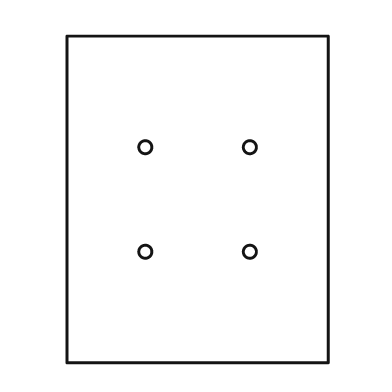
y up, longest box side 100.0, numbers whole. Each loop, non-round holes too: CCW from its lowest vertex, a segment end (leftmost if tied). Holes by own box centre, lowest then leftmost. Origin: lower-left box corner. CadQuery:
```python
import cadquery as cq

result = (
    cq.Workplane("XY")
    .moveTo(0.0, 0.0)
    .lineTo(80.0, 0.0)
    .lineTo(80.0, 100.0)
    .lineTo(0.0, 100.0)
    .close()
    .moveTo(24.0, 34.0)
    .circle(2.0)
    .moveTo(56.0, 34.0)
    .circle(2.0)
    .moveTo(24.0, 66.0)
    .circle(2.0)
    .moveTo(56.0, 66.0)
    .circle(2.0)
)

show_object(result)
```